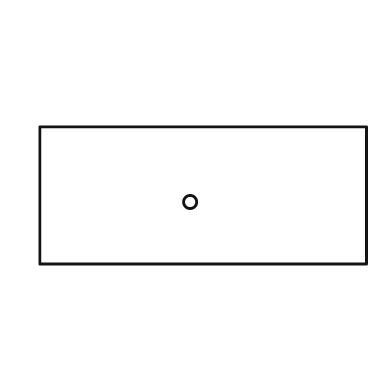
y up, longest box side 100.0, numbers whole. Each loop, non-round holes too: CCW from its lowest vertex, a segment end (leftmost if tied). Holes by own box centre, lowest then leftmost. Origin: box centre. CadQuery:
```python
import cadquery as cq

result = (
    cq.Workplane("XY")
    .moveTo(-50.0, -21.0)
    .lineTo(50.0, -21.0)
    .lineTo(50.0, 21.0)
    .lineTo(-50.0, 21.0)
    .close()
    .moveTo(-4.0, -2.0)
    .circle(2.0)
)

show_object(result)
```